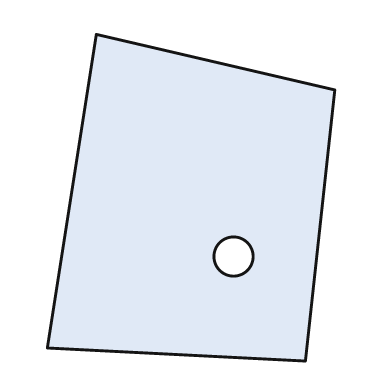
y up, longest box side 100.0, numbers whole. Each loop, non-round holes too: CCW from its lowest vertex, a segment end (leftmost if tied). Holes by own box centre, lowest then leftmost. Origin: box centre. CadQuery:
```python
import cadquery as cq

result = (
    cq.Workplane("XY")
    .moveTo(35.0, -50.0)
    .lineTo(44.0, 33.0)
    .lineTo(-29.0, 50.0)
    .lineTo(-44.0, -46.0)
    .close()
    .moveTo(13.0, -18.0)
    .circle(6.0)
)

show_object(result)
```